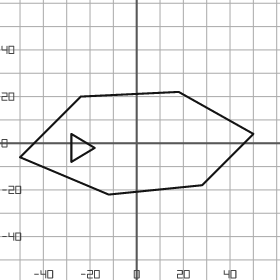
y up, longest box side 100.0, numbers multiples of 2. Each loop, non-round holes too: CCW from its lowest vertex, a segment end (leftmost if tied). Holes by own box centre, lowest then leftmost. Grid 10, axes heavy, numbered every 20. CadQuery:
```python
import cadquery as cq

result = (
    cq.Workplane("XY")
    .moveTo(-12.0, -22.0)
    .lineTo(28.0, -18.0)
    .lineTo(50.0, 4.0)
    .lineTo(18.0, 22.0)
    .lineTo(-24.0, 20.0)
    .lineTo(-50.0, -6.0)
    .close()
    .moveTo(-28.0, -8.0)
    .lineTo(-18.0, -2.0)
    .lineTo(-28.0, 4.0)
    .close()
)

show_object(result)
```